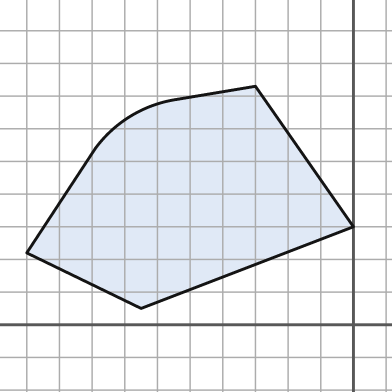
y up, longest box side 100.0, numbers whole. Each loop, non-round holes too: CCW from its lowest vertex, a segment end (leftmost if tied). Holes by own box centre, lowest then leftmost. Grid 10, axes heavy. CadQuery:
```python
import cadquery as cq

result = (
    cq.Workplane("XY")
    .moveTo(-65.0, 5.0)
    .lineTo(0.0, 30.0)
    .lineTo(-30.0, 73.0)
    .lineTo(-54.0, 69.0)
    .threePointArc((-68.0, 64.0), (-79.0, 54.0))
    .lineTo(-100.0, 22.0)
    .close()
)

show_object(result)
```